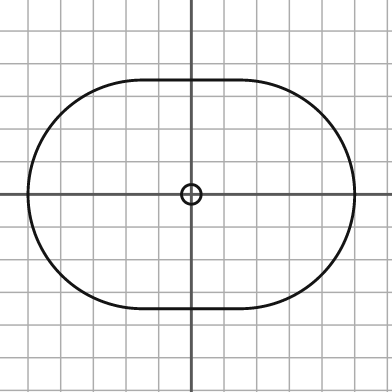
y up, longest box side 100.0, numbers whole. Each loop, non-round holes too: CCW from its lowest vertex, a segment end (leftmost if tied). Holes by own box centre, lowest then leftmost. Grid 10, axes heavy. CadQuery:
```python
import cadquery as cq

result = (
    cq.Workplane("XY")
    .moveTo(-15.0, -35.0)
    .lineTo(15.0, -35.0)
    .threePointArc((50.0, 0.0), (15.0, 35.0))
    .lineTo(-15.0, 35.0)
    .threePointArc((-50.0, 0.0), (-15.0, -35.0))
    .close()
    .moveTo(0.0, 0.0)
    .circle(3.0)
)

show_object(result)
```